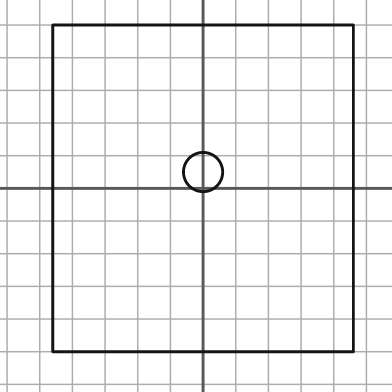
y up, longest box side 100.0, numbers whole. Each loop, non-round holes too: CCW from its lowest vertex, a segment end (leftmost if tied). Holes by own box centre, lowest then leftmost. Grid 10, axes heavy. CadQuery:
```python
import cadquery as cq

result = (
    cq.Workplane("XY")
    .moveTo(-46.0, -50.0)
    .lineTo(46.0, -50.0)
    .lineTo(46.0, 50.0)
    .lineTo(-46.0, 50.0)
    .close()
    .moveTo(0.0, 5.0)
    .circle(6.0)
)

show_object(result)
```